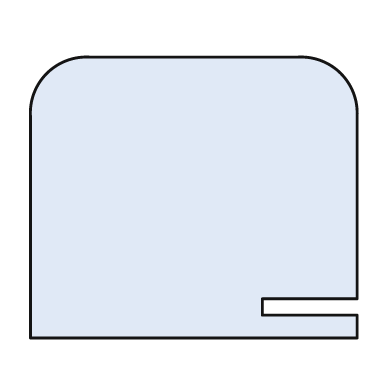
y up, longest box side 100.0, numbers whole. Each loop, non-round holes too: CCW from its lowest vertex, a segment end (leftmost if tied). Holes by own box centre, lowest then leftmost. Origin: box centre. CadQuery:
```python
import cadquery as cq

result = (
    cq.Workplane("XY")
    .moveTo(-50.0, -43.0)
    .lineTo(50.0, -43.0)
    .lineTo(50.0, -36.0)
    .lineTo(21.0, -36.0)
    .lineTo(21.0, -31.0)
    .lineTo(50.0, -31.0)
    .lineTo(50.0, 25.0)
    .threePointArc((45.0, 38.0), (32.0, 43.0))
    .lineTo(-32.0, 43.0)
    .threePointArc((-45.0, 38.0), (-50.0, 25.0))
    .close()
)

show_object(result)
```